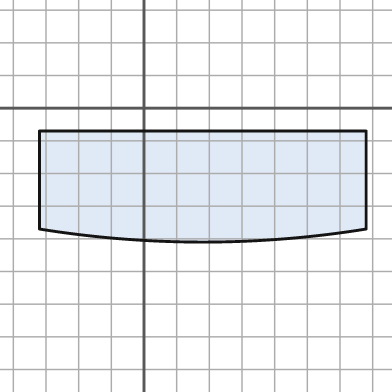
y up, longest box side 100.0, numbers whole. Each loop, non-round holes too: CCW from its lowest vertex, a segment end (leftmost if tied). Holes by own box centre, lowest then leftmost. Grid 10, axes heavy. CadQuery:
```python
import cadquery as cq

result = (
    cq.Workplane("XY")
    .moveTo(-32.0, -37.0)
    .threePointArc((18.0, -41.0), (68.0, -37.0))
    .lineTo(68.0, -7.0)
    .lineTo(-32.0, -7.0)
    .close()
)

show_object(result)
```